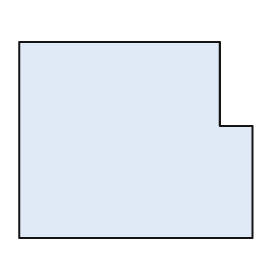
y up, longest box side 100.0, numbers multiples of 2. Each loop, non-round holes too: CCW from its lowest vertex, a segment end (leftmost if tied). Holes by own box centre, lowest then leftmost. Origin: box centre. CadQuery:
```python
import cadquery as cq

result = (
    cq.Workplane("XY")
    .moveTo(-50.0, -42.0)
    .lineTo(50.0, -42.0)
    .lineTo(50.0, 6.0)
    .lineTo(36.0, 6.0)
    .lineTo(36.0, 42.0)
    .lineTo(-50.0, 42.0)
    .close()
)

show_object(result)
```